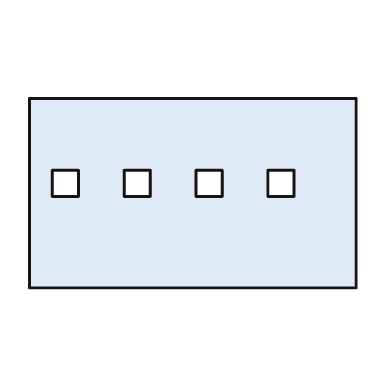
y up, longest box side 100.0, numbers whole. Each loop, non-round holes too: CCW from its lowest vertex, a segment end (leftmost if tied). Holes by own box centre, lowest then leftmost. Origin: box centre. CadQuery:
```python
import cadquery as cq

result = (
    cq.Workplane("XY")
    .moveTo(-50.0, -29.0)
    .lineTo(50.0, -29.0)
    .lineTo(50.0, 29.0)
    .lineTo(-50.0, 29.0)
    .close()
    .moveTo(-43.0, -1.0)
    .lineTo(-35.0, -1.0)
    .lineTo(-35.0, 7.0)
    .lineTo(-43.0, 7.0)
    .close()
    .moveTo(-21.0, -1.0)
    .lineTo(-13.0, -1.0)
    .lineTo(-13.0, 7.0)
    .lineTo(-21.0, 7.0)
    .close()
    .moveTo(1.0, -1.0)
    .lineTo(9.0, -1.0)
    .lineTo(9.0, 7.0)
    .lineTo(1.0, 7.0)
    .close()
    .moveTo(23.0, -1.0)
    .lineTo(31.0, -1.0)
    .lineTo(31.0, 7.0)
    .lineTo(23.0, 7.0)
    .close()
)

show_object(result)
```